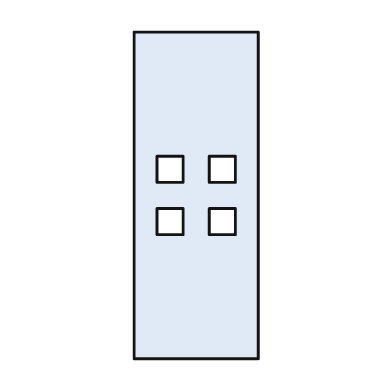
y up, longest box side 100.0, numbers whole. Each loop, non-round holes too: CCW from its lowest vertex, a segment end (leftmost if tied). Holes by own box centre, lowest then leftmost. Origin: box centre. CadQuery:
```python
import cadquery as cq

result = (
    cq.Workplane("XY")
    .moveTo(-19.0, -50.0)
    .lineTo(19.0, -50.0)
    .lineTo(19.0, 50.0)
    .lineTo(-19.0, 50.0)
    .close()
    .moveTo(-12.0, -12.0)
    .lineTo(-4.0, -12.0)
    .lineTo(-4.0, -4.0)
    .lineTo(-12.0, -4.0)
    .close()
    .moveTo(4.0, -12.0)
    .lineTo(12.0, -12.0)
    .lineTo(12.0, -4.0)
    .lineTo(4.0, -4.0)
    .close()
    .moveTo(-12.0, 4.0)
    .lineTo(-4.0, 4.0)
    .lineTo(-4.0, 12.0)
    .lineTo(-12.0, 12.0)
    .close()
    .moveTo(4.0, 4.0)
    .lineTo(12.0, 4.0)
    .lineTo(12.0, 12.0)
    .lineTo(4.0, 12.0)
    .close()
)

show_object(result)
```